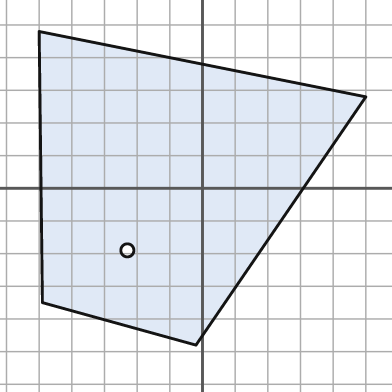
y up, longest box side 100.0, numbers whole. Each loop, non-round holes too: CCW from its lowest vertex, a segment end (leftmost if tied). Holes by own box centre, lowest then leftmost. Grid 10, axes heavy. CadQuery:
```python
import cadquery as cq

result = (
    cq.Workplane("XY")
    .moveTo(-2.0, -48.0)
    .lineTo(50.0, 28.0)
    .lineTo(-50.0, 48.0)
    .lineTo(-49.0, -35.0)
    .close()
    .moveTo(-23.0, -19.0)
    .circle(2.0)
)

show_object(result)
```